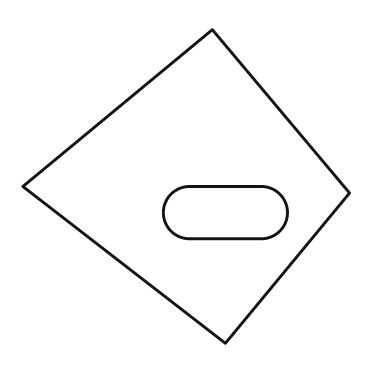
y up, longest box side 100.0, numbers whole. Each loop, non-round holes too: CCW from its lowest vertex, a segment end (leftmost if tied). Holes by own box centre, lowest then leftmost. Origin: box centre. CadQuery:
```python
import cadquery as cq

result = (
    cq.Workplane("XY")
    .moveTo(12.0, -48.0)
    .lineTo(50.0, -2.0)
    .lineTo(8.0, 48.0)
    .lineTo(-50.0, 0.0)
    .close()
    .moveTo(1.0, -16.0)
    .lineTo(23.0, -16.0)
    .threePointArc((31.0, -8.0), (23.0, 0.0))
    .lineTo(1.0, 0.0)
    .threePointArc((-7.0, -8.0), (1.0, -16.0))
    .close()
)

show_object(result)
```